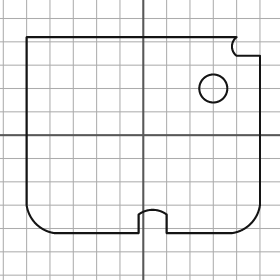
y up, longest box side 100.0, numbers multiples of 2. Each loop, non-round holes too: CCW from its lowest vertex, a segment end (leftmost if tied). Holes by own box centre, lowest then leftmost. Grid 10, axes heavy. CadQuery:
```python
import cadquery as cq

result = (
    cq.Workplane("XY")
    .moveTo(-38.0, -42.0)
    .lineTo(-2.0, -42.0)
    .lineTo(-2.0, -34.0)
    .threePointArc((4.0, -32.0), (10.0, -34.0))
    .lineTo(10.0, -42.0)
    .lineTo(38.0, -42.0)
    .threePointArc((46.0, -38.0), (50.0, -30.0))
    .lineTo(50.0, 34.0)
    .lineTo(40.0, 34.0)
    .threePointArc((38.0, 38.0), (40.0, 42.0))
    .lineTo(-50.0, 42.0)
    .lineTo(-50.0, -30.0)
    .threePointArc((-46.0, -38.0), (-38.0, -42.0))
    .close()
    .moveTo(30.0, 20.0)
    .circle(6.0)
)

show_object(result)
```